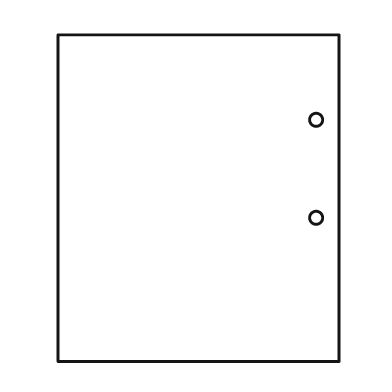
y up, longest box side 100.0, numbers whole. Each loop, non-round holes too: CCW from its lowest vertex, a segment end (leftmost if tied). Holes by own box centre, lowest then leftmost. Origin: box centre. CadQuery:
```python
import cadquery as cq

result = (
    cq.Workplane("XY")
    .moveTo(-43.0, -50.0)
    .lineTo(43.0, -50.0)
    .lineTo(43.0, 50.0)
    .lineTo(-43.0, 50.0)
    .close()
    .moveTo(36.0, -6.0)
    .circle(2.0)
    .moveTo(36.0, 24.0)
    .circle(2.0)
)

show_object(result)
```